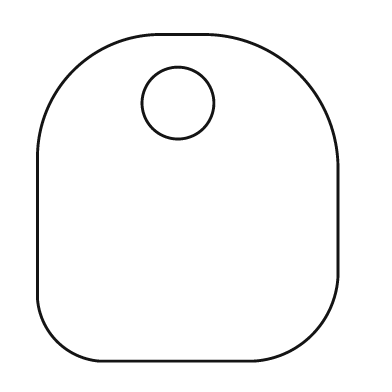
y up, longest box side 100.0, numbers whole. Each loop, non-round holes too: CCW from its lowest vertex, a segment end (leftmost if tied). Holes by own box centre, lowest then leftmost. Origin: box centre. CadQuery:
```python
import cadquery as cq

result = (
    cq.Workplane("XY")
    .moveTo(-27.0, -50.0)
    .lineTo(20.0, -50.0)
    .threePointArc((38.0, -42.0), (46.0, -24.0))
    .lineTo(46.0, 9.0)
    .threePointArc((34.0, 38.0), (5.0, 50.0))
    .lineTo(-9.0, 50.0)
    .threePointArc((-35.0, 39.0), (-46.0, 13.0))
    .lineTo(-46.0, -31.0)
    .threePointArc((-40.0, -44.0), (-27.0, -50.0))
    .close()
    .moveTo(-3.0, 29.0)
    .circle(11.0)
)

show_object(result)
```